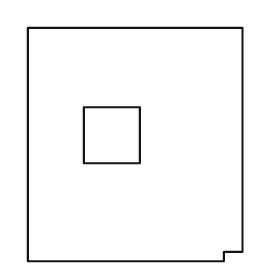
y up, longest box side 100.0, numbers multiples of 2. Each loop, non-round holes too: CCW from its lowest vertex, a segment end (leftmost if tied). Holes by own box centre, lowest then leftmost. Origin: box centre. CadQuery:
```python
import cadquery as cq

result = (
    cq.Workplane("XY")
    .moveTo(-46.0, -50.0)
    .lineTo(38.0, -50.0)
    .lineTo(38.0, -46.0)
    .lineTo(46.0, -46.0)
    .lineTo(46.0, 50.0)
    .lineTo(-46.0, 50.0)
    .close()
    .moveTo(-22.0, -8.0)
    .lineTo(2.0, -8.0)
    .lineTo(2.0, 16.0)
    .lineTo(-22.0, 16.0)
    .close()
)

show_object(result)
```